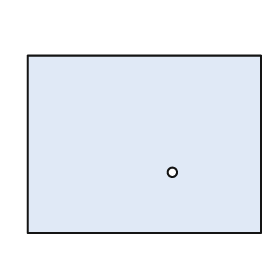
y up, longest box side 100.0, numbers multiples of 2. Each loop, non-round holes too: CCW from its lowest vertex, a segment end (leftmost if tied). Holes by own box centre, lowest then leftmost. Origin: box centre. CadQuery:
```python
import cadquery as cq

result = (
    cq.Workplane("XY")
    .moveTo(-50.0, -38.0)
    .lineTo(50.0, -38.0)
    .lineTo(50.0, 38.0)
    .lineTo(-50.0, 38.0)
    .close()
    .moveTo(12.0, -12.0)
    .circle(2.0)
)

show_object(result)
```